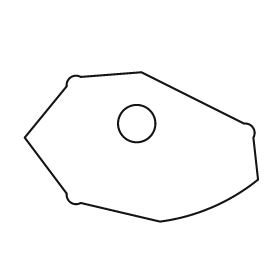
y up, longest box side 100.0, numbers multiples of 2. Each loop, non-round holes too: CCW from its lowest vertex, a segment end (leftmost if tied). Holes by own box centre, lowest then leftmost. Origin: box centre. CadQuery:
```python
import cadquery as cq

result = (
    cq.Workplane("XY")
    .moveTo(8.0, -32.0)
    .threePointArc((30.0, -26.0), (50.0, -14.0))
    .lineTo(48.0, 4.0)
    .threePointArc((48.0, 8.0), (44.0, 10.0))
    .lineTo(0.0, 32.0)
    .lineTo(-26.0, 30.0)
    .threePointArc((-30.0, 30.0), (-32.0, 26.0))
    .lineTo(-50.0, 4.0)
    .lineTo(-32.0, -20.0)
    .threePointArc((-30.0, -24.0), (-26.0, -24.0))
    .close()
    .moveTo(-2.0, 10.0)
    .circle(8.0)
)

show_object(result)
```